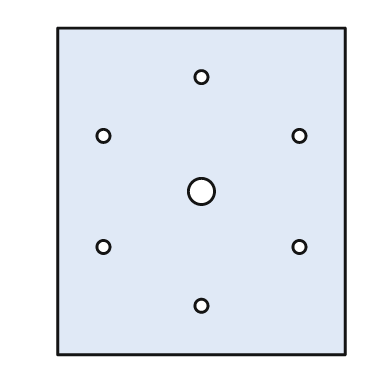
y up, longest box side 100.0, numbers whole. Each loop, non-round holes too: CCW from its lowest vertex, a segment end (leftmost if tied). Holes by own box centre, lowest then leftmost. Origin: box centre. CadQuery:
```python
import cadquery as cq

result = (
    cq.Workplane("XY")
    .moveTo(-44.0, -50.0)
    .lineTo(44.0, -50.0)
    .lineTo(44.0, 50.0)
    .lineTo(-44.0, 50.0)
    .close()
    .moveTo(0.0, -35.0)
    .circle(2.0)
    .moveTo(-30.0, -17.0)
    .circle(2.0)
    .moveTo(30.0, -17.0)
    .circle(2.0)
    .moveTo(0.0, 0.0)
    .circle(4.0)
    .moveTo(-30.0, 17.0)
    .circle(2.0)
    .moveTo(30.0, 17.0)
    .circle(2.0)
    .moveTo(0.0, 35.0)
    .circle(2.0)
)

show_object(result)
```